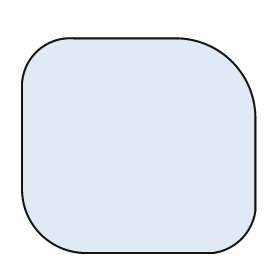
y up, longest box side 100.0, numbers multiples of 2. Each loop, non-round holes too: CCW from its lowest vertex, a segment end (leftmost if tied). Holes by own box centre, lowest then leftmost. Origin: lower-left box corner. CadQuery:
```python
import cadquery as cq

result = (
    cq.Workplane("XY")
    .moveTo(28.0, 0.0)
    .lineTo(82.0, 0.0)
    .threePointArc((94.0, 6.0), (100.0, 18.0))
    .lineTo(100.0, 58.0)
    .threePointArc((90.0, 82.0), (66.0, 92.0))
    .lineTo(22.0, 92.0)
    .threePointArc((6.0, 86.0), (0.0, 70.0))
    .lineTo(0.0, 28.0)
    .threePointArc((8.0, 8.0), (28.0, 0.0))
    .close()
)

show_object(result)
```